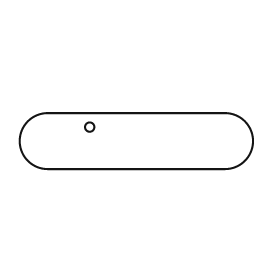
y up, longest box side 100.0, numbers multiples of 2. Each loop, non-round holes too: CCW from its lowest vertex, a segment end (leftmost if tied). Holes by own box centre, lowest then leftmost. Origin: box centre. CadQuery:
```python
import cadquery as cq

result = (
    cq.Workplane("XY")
    .moveTo(-38.0, -12.0)
    .lineTo(38.0, -12.0)
    .threePointArc((50.0, 0.0), (38.0, 12.0))
    .lineTo(-38.0, 12.0)
    .threePointArc((-50.0, 0.0), (-38.0, -12.0))
    .close()
    .moveTo(-20.0, 6.0)
    .circle(2.0)
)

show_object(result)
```